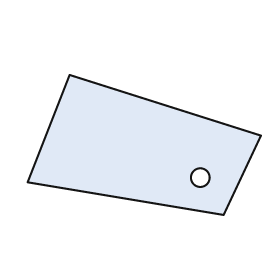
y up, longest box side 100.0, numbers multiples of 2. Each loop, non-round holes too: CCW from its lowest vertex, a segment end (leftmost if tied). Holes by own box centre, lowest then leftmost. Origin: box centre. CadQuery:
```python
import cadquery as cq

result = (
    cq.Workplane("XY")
    .moveTo(34.0, -30.0)
    .lineTo(50.0, 4.0)
    .lineTo(-32.0, 30.0)
    .lineTo(-50.0, -16.0)
    .close()
    .moveTo(24.0, -14.0)
    .circle(4.0)
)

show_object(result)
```